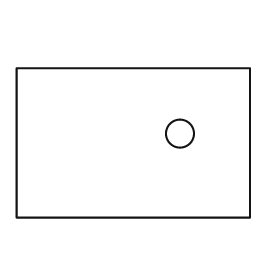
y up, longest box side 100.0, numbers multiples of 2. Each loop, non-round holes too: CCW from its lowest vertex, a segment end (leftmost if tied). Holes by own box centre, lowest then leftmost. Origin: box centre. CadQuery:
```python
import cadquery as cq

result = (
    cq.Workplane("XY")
    .moveTo(-50.0, -32.0)
    .lineTo(50.0, -32.0)
    .lineTo(50.0, 32.0)
    .lineTo(-50.0, 32.0)
    .close()
    .moveTo(20.0, 4.0)
    .circle(6.0)
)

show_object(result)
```